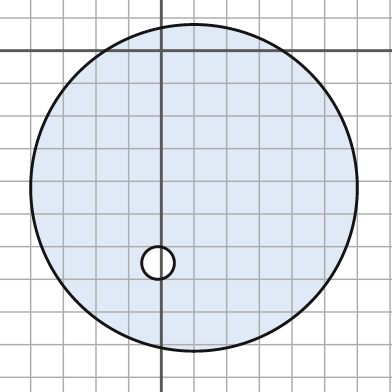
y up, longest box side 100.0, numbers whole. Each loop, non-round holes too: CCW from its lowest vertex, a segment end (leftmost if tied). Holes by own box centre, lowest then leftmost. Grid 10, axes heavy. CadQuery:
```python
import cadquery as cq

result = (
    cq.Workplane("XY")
    .moveTo(10.0, -42.0)
    .circle(50.0)
    .moveTo(-1.0, -65.0)
    .circle(5.0)
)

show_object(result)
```